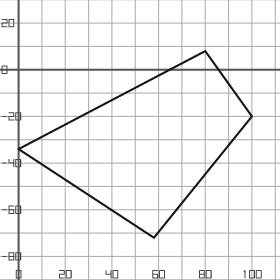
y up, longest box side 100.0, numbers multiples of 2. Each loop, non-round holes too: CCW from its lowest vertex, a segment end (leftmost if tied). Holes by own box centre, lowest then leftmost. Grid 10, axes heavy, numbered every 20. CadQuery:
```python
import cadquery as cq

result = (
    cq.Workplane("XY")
    .moveTo(58.0, -72.0)
    .lineTo(100.0, -20.0)
    .lineTo(80.0, 8.0)
    .lineTo(0.0, -34.0)
    .close()
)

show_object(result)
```